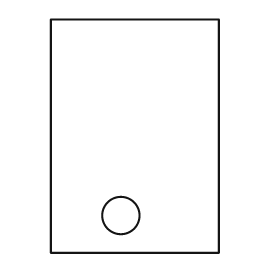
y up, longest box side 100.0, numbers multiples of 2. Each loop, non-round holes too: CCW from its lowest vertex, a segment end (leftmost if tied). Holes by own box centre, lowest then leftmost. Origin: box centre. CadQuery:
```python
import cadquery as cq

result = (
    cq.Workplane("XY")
    .moveTo(-36.0, -50.0)
    .lineTo(36.0, -50.0)
    .lineTo(36.0, 50.0)
    .lineTo(-36.0, 50.0)
    .close()
    .moveTo(-6.0, -34.0)
    .circle(8.0)
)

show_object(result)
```